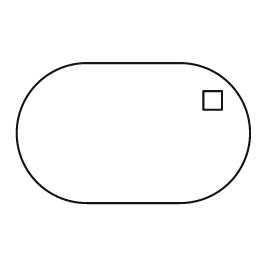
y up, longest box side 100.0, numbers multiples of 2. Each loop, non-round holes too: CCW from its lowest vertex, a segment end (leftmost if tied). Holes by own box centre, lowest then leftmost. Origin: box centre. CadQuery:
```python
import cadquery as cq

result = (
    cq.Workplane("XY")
    .moveTo(-20.0, -30.0)
    .lineTo(20.0, -30.0)
    .threePointArc((50.0, 0.0), (20.0, 30.0))
    .lineTo(-20.0, 30.0)
    .threePointArc((-50.0, 0.0), (-20.0, -30.0))
    .close()
    .moveTo(30.0, 10.0)
    .lineTo(38.0, 10.0)
    .lineTo(38.0, 18.0)
    .lineTo(30.0, 18.0)
    .close()
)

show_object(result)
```